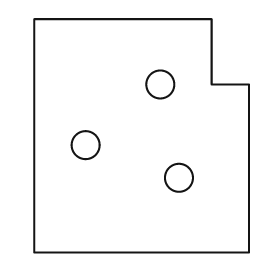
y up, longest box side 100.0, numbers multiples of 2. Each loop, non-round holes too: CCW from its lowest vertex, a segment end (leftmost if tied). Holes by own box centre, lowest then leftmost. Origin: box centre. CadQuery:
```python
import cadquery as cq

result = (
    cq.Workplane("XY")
    .moveTo(-46.0, -50.0)
    .lineTo(46.0, -50.0)
    .lineTo(46.0, 22.0)
    .lineTo(30.0, 22.0)
    .lineTo(30.0, 50.0)
    .lineTo(-46.0, 50.0)
    .close()
    .moveTo(16.0, -18.0)
    .circle(6.0)
    .moveTo(-24.0, -4.0)
    .circle(6.0)
    .moveTo(8.0, 22.0)
    .circle(6.0)
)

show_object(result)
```